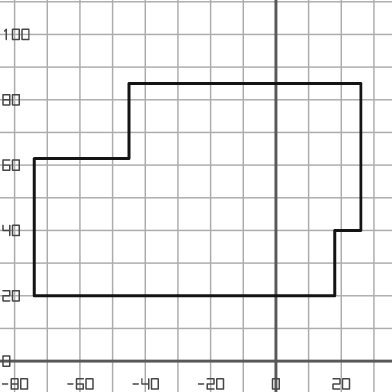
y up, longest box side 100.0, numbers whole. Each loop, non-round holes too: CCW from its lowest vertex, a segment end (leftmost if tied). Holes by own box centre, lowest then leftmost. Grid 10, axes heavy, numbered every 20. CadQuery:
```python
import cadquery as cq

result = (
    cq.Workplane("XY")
    .moveTo(-74.0, 20.0)
    .lineTo(18.0, 20.0)
    .lineTo(18.0, 40.0)
    .lineTo(26.0, 40.0)
    .lineTo(26.0, 85.0)
    .lineTo(-45.0, 85.0)
    .lineTo(-45.0, 62.0)
    .lineTo(-74.0, 62.0)
    .close()
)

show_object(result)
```